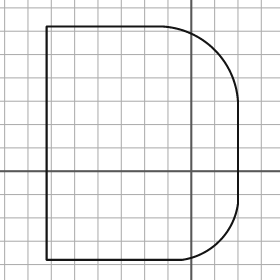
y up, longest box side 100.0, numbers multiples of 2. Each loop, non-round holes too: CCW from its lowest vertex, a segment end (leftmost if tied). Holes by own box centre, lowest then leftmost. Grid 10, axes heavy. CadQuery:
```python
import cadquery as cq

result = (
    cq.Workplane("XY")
    .moveTo(-62.0, -38.0)
    .lineTo(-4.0, -38.0)
    .threePointArc((12.0, -30.0), (20.0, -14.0))
    .lineTo(20.0, 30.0)
    .threePointArc((10.0, 52.0), (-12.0, 62.0))
    .lineTo(-62.0, 62.0)
    .close()
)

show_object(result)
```